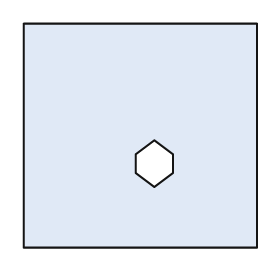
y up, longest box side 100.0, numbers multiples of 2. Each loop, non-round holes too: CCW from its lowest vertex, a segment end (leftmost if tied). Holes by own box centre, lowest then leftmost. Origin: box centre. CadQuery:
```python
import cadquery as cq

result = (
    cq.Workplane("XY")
    .moveTo(-50.0, -48.0)
    .lineTo(50.0, -48.0)
    .lineTo(50.0, 48.0)
    .lineTo(-50.0, 48.0)
    .close()
    .moveTo(6.0, -22.0)
    .lineTo(14.0, -16.0)
    .lineTo(14.0, -8.0)
    .lineTo(6.0, -2.0)
    .lineTo(-2.0, -8.0)
    .lineTo(-2.0, -16.0)
    .close()
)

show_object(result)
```